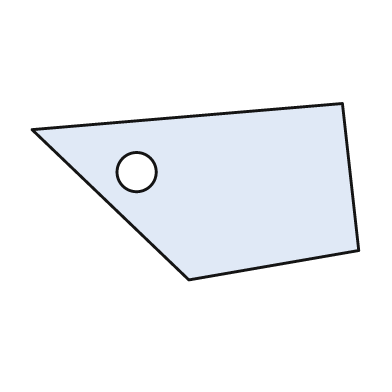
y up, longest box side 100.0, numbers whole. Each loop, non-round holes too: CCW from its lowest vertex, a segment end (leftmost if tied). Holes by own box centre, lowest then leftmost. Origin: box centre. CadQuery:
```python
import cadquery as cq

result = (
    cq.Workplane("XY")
    .moveTo(-2.0, -27.0)
    .lineTo(50.0, -18.0)
    .lineTo(45.0, 27.0)
    .lineTo(-50.0, 19.0)
    .close()
    .moveTo(-18.0, 6.0)
    .circle(6.0)
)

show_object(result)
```